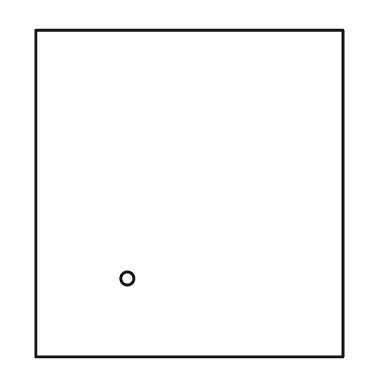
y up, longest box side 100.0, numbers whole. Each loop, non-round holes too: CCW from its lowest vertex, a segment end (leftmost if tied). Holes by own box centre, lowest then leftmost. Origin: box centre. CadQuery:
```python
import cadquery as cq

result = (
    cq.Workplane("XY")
    .moveTo(-47.0, -50.0)
    .lineTo(47.0, -50.0)
    .lineTo(47.0, 50.0)
    .lineTo(-47.0, 50.0)
    .close()
    .moveTo(-19.0, -26.0)
    .circle(2.0)
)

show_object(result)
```